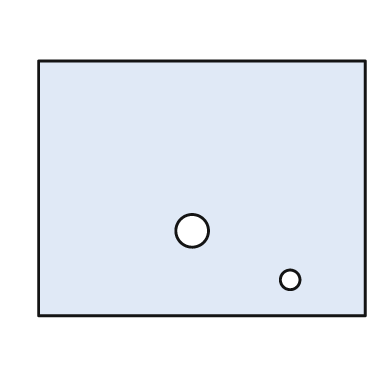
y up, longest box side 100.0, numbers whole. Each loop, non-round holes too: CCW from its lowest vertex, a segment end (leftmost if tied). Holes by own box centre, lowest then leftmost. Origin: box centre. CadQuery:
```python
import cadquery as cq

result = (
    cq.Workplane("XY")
    .moveTo(-50.0, -39.0)
    .lineTo(50.0, -39.0)
    .lineTo(50.0, 39.0)
    .lineTo(-50.0, 39.0)
    .close()
    .moveTo(27.0, -28.0)
    .circle(3.0)
    .moveTo(-3.0, -13.0)
    .circle(5.0)
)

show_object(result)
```